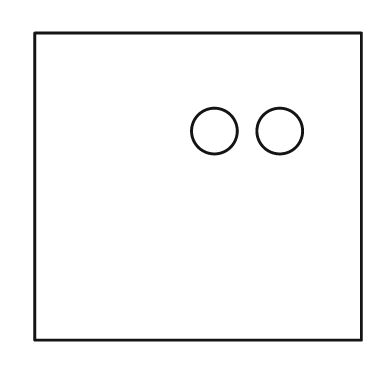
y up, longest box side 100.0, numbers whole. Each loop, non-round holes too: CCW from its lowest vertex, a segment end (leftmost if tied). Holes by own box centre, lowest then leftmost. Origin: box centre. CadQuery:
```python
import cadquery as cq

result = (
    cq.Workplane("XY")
    .moveTo(-50.0, -47.0)
    .lineTo(50.0, -47.0)
    .lineTo(50.0, 47.0)
    .lineTo(-50.0, 47.0)
    .close()
    .moveTo(5.0, 17.0)
    .circle(7.0)
    .moveTo(25.0, 17.0)
    .circle(7.0)
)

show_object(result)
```